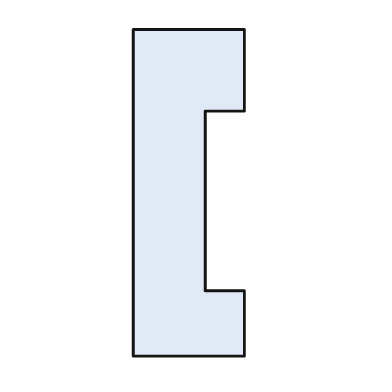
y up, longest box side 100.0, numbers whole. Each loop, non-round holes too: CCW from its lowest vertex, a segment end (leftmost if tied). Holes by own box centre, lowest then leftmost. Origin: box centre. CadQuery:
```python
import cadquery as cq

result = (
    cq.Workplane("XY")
    .moveTo(-17.0, -50.0)
    .lineTo(17.0, -50.0)
    .lineTo(17.0, -30.0)
    .lineTo(5.0, -30.0)
    .lineTo(5.0, 25.0)
    .lineTo(17.0, 25.0)
    .lineTo(17.0, 50.0)
    .lineTo(-17.0, 50.0)
    .close()
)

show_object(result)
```